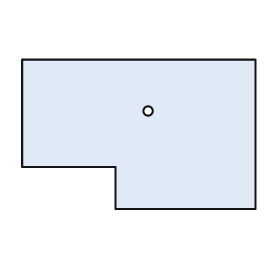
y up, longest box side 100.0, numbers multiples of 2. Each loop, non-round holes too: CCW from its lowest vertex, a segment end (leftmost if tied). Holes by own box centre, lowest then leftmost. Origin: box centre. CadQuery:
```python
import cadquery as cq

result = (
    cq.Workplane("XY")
    .moveTo(-10.0, -32.0)
    .lineTo(50.0, -32.0)
    .lineTo(50.0, 32.0)
    .lineTo(-50.0, 32.0)
    .lineTo(-50.0, -14.0)
    .lineTo(-10.0, -14.0)
    .close()
    .moveTo(4.0, 10.0)
    .circle(2.0)
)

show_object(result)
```